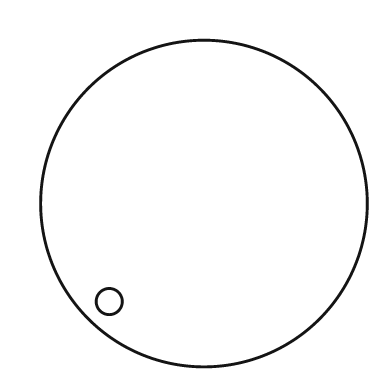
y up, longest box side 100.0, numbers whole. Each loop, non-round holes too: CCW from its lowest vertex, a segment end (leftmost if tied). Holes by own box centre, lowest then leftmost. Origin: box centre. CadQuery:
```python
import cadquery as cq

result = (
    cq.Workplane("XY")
    .moveTo(0.0, 0.0)
    .circle(50.0)
    .moveTo(-29.0, -30.0)
    .circle(4.0)
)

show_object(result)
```